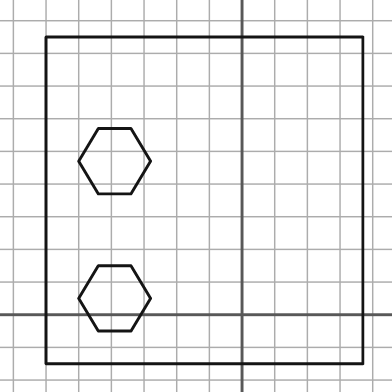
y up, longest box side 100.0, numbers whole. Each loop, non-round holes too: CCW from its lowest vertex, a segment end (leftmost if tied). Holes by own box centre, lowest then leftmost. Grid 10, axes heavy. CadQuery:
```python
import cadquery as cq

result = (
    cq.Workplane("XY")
    .moveTo(-60.0, -15.0)
    .lineTo(37.0, -15.0)
    .lineTo(37.0, 85.0)
    .lineTo(-60.0, 85.0)
    .close()
    .moveTo(-44.0, -5.0)
    .lineTo(-34.0, -5.0)
    .lineTo(-28.0, 5.0)
    .lineTo(-34.0, 15.0)
    .lineTo(-44.0, 15.0)
    .lineTo(-50.0, 5.0)
    .close()
    .moveTo(-44.0, 37.0)
    .lineTo(-34.0, 37.0)
    .lineTo(-28.0, 47.0)
    .lineTo(-34.0, 57.0)
    .lineTo(-44.0, 57.0)
    .lineTo(-50.0, 47.0)
    .close()
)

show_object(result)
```